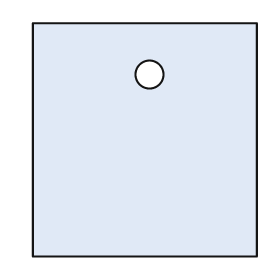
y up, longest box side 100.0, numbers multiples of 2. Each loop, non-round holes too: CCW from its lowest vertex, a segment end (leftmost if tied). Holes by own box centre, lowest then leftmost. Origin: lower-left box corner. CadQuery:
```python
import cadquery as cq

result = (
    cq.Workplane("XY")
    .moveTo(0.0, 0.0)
    .lineTo(96.0, 0.0)
    .lineTo(96.0, 100.0)
    .lineTo(0.0, 100.0)
    .close()
    .moveTo(50.0, 78.0)
    .circle(6.0)
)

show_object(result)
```